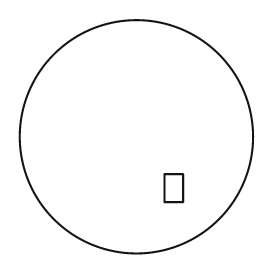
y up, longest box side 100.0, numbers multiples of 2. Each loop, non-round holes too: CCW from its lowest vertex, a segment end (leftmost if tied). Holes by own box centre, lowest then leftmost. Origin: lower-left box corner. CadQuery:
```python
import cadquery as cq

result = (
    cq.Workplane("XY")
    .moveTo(50.0, 50.0)
    .circle(50.0)
    .moveTo(62.0, 22.0)
    .lineTo(70.0, 22.0)
    .lineTo(70.0, 34.0)
    .lineTo(62.0, 34.0)
    .close()
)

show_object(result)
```